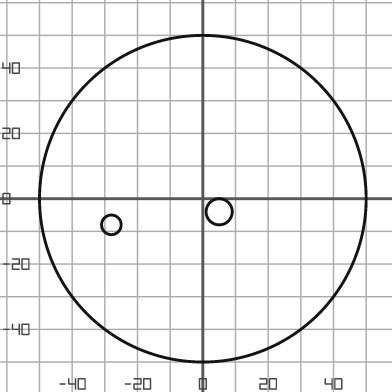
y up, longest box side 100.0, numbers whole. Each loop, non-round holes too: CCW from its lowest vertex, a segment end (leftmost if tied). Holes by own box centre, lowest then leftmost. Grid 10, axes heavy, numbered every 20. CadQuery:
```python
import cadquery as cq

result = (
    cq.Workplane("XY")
    .moveTo(0.0, 0.0)
    .circle(50.0)
    .moveTo(-28.0, -8.0)
    .circle(3.0)
    .moveTo(5.0, -4.0)
    .circle(4.0)
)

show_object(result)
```